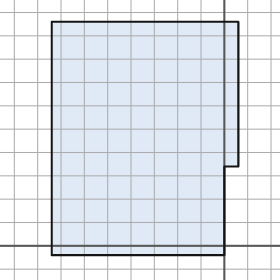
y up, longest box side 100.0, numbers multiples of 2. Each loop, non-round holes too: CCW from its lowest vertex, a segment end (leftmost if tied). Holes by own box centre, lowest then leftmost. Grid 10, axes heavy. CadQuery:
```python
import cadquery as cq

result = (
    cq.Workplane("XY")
    .moveTo(-74.0, -4.0)
    .lineTo(0.0, -4.0)
    .lineTo(0.0, 34.0)
    .lineTo(6.0, 34.0)
    .lineTo(6.0, 96.0)
    .lineTo(-74.0, 96.0)
    .close()
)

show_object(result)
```